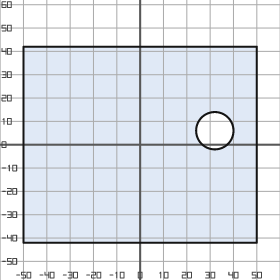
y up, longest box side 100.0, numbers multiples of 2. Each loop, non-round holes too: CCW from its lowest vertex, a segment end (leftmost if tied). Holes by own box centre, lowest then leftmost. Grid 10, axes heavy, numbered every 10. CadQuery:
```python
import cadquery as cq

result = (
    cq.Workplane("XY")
    .moveTo(-50.0, -42.0)
    .lineTo(50.0, -42.0)
    .lineTo(50.0, 42.0)
    .lineTo(-50.0, 42.0)
    .close()
    .moveTo(32.0, 6.0)
    .circle(8.0)
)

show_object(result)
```